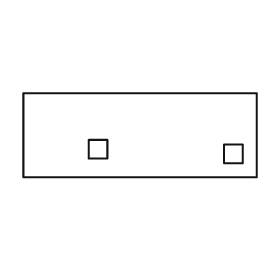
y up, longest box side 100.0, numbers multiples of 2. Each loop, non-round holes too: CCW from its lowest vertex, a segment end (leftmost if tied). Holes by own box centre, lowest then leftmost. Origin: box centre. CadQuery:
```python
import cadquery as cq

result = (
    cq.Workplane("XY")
    .moveTo(-50.0, -18.0)
    .lineTo(50.0, -18.0)
    .lineTo(50.0, 18.0)
    .lineTo(-50.0, 18.0)
    .close()
    .moveTo(36.0, -12.0)
    .lineTo(44.0, -12.0)
    .lineTo(44.0, -4.0)
    .lineTo(36.0, -4.0)
    .close()
    .moveTo(-22.0, -10.0)
    .lineTo(-14.0, -10.0)
    .lineTo(-14.0, -2.0)
    .lineTo(-22.0, -2.0)
    .close()
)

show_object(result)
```